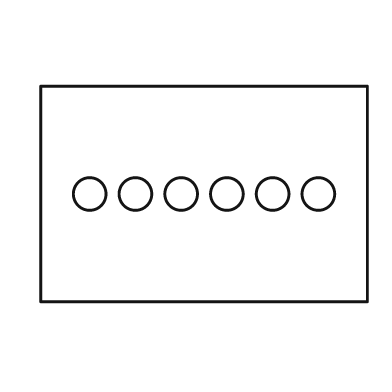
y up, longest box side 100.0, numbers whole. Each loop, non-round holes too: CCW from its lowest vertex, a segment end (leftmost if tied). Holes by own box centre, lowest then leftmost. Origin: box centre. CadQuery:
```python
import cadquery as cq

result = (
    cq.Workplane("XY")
    .moveTo(-50.0, -33.0)
    .lineTo(50.0, -33.0)
    .lineTo(50.0, 33.0)
    .lineTo(-50.0, 33.0)
    .close()
    .moveTo(-35.0, 0.0)
    .circle(5.0)
    .moveTo(-21.0, 0.0)
    .circle(5.0)
    .moveTo(-7.0, 0.0)
    .circle(5.0)
    .moveTo(7.0, 0.0)
    .circle(5.0)
    .moveTo(21.0, 0.0)
    .circle(5.0)
    .moveTo(35.0, 0.0)
    .circle(5.0)
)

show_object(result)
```